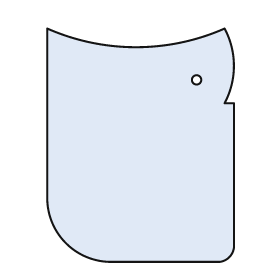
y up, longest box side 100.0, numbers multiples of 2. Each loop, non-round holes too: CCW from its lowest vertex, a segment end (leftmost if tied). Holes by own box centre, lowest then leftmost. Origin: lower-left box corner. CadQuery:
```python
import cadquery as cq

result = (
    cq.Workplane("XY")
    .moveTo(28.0, 0.0)
    .lineTo(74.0, 0.0)
    .threePointArc((78.0, 2.0), (80.0, 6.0))
    .lineTo(80.0, 68.0)
    .lineTo(76.0, 68.0)
    .threePointArc((80.0, 84.0), (76.0, 100.0))
    .threePointArc((38.0, 92.0), (0.0, 100.0))
    .lineTo(0.0, 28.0)
    .threePointArc((8.0, 8.0), (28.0, 0.0))
    .close()
    .moveTo(64.0, 78.0)
    .circle(2.0)
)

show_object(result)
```